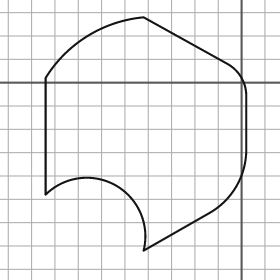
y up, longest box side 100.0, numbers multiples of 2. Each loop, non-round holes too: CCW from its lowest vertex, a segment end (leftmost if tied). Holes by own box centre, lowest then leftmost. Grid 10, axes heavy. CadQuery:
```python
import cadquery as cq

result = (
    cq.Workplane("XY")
    .moveTo(-42.0, -72.0)
    .lineTo(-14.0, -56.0)
    .threePointArc((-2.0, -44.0), (2.0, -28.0))
    .lineTo(2.0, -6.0)
    .threePointArc((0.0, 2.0), (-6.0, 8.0))
    .lineTo(-42.0, 28.0)
    .threePointArc((-66.0, 20.0), (-84.0, 2.0))
    .lineTo(-84.0, -48.0)
    .threePointArc((-54.0, -44.0), (-42.0, -72.0))
    .close()
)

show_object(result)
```